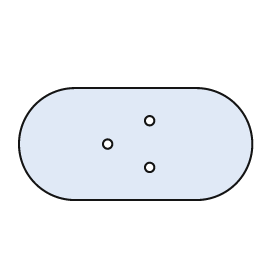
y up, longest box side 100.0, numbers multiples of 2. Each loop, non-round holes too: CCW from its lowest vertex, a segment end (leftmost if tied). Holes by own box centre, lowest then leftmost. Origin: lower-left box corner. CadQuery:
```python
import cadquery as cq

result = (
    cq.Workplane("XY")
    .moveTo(24.0, 0.0)
    .lineTo(76.0, 0.0)
    .threePointArc((100.0, 24.0), (76.0, 48.0))
    .lineTo(24.0, 48.0)
    .threePointArc((0.0, 24.0), (24.0, 0.0))
    .close()
    .moveTo(56.0, 14.0)
    .circle(2.0)
    .moveTo(38.0, 24.0)
    .circle(2.0)
    .moveTo(56.0, 34.0)
    .circle(2.0)
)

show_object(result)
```